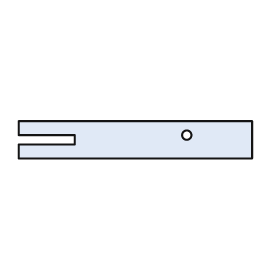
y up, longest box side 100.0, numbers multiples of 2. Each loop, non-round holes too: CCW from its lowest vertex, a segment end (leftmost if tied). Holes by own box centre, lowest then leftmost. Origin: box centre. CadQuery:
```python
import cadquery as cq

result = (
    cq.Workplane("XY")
    .moveTo(-50.0, -8.0)
    .lineTo(50.0, -8.0)
    .lineTo(50.0, 8.0)
    .lineTo(-50.0, 8.0)
    .lineTo(-50.0, 2.0)
    .lineTo(-26.0, 2.0)
    .lineTo(-26.0, -2.0)
    .lineTo(-50.0, -2.0)
    .close()
    .moveTo(22.0, 2.0)
    .circle(2.0)
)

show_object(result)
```